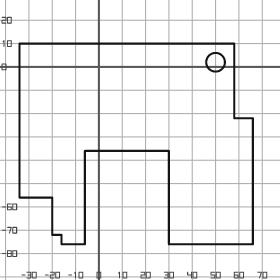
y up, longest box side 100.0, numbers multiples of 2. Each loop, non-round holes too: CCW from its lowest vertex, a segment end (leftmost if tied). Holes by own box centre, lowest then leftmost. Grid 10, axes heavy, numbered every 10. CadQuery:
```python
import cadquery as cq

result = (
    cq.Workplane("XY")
    .moveTo(-16.0, -76.0)
    .lineTo(-6.0, -76.0)
    .lineTo(-6.0, -36.0)
    .lineTo(30.0, -36.0)
    .lineTo(30.0, -76.0)
    .lineTo(66.0, -76.0)
    .lineTo(66.0, -22.0)
    .lineTo(58.0, -22.0)
    .lineTo(58.0, 10.0)
    .lineTo(-34.0, 10.0)
    .lineTo(-34.0, -56.0)
    .lineTo(-20.0, -56.0)
    .lineTo(-20.0, -72.0)
    .lineTo(-16.0, -72.0)
    .close()
    .moveTo(50.0, 2.0)
    .circle(4.0)
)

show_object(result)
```